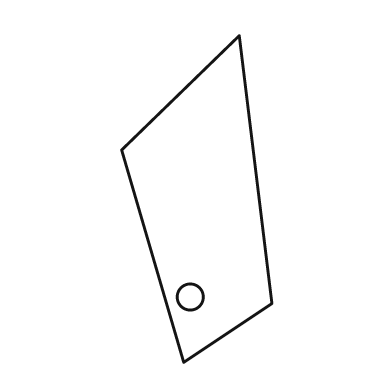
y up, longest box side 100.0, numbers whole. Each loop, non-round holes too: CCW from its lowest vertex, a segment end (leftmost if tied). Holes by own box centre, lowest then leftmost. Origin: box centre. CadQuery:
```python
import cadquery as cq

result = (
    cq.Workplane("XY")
    .moveTo(-4.0, -50.0)
    .lineTo(23.0, -32.0)
    .lineTo(13.0, 50.0)
    .lineTo(-23.0, 15.0)
    .close()
    .moveTo(-2.0, -30.0)
    .circle(4.0)
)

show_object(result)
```